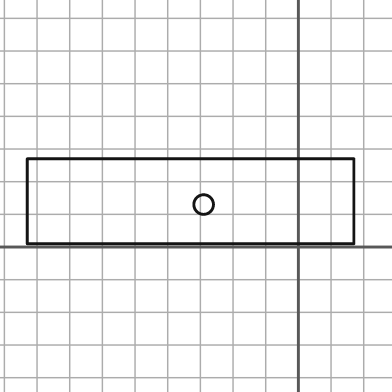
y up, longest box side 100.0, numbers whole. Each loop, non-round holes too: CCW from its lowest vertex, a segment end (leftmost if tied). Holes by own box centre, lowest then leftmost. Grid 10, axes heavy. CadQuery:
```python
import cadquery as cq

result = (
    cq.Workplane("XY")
    .moveTo(-83.0, 1.0)
    .lineTo(17.0, 1.0)
    .lineTo(17.0, 27.0)
    .lineTo(-83.0, 27.0)
    .close()
    .moveTo(-29.0, 13.0)
    .circle(3.0)
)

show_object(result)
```